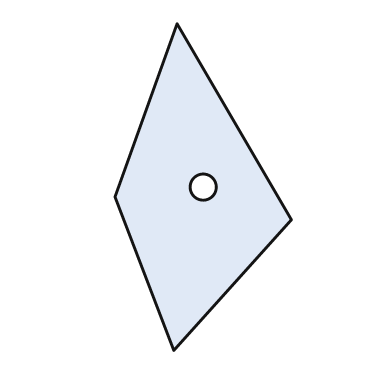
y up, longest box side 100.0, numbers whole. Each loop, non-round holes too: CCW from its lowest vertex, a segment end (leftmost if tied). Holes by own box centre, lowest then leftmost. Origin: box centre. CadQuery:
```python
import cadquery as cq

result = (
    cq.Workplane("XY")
    .moveTo(-9.0, -50.0)
    .lineTo(27.0, -10.0)
    .lineTo(-8.0, 50.0)
    .lineTo(-27.0, -3.0)
    .close()
    .moveTo(0.0, 0.0)
    .circle(4.0)
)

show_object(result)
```